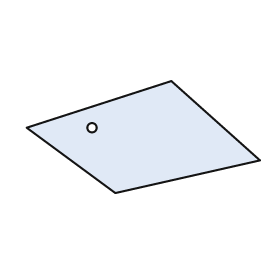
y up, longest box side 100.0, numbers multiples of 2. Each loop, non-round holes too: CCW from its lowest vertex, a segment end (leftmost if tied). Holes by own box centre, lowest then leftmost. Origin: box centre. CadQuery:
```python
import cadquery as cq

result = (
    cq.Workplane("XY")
    .moveTo(-12.0, -24.0)
    .lineTo(50.0, -10.0)
    .lineTo(12.0, 24.0)
    .lineTo(-50.0, 4.0)
    .close()
    .moveTo(-22.0, 4.0)
    .circle(2.0)
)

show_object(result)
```